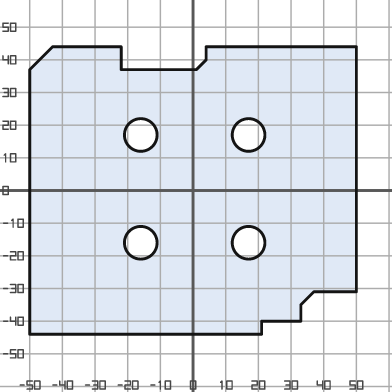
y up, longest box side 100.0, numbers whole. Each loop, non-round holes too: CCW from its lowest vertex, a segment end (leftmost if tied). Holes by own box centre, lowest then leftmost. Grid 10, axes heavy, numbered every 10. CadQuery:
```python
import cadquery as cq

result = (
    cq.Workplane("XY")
    .moveTo(-50.0, -44.0)
    .lineTo(21.0, -44.0)
    .lineTo(21.0, -40.0)
    .lineTo(33.0, -40.0)
    .lineTo(33.0, -35.0)
    .lineTo(37.0, -31.0)
    .lineTo(50.0, -31.0)
    .lineTo(50.0, 44.0)
    .lineTo(4.0, 44.0)
    .lineTo(4.0, 40.0)
    .lineTo(1.0, 37.0)
    .lineTo(-22.0, 37.0)
    .lineTo(-22.0, 44.0)
    .lineTo(-43.0, 44.0)
    .lineTo(-50.0, 37.0)
    .close()
    .moveTo(-16.0, -16.0)
    .circle(5.0)
    .moveTo(17.0, -16.0)
    .circle(5.0)
    .moveTo(-16.0, 17.0)
    .circle(5.0)
    .moveTo(17.0, 17.0)
    .circle(5.0)
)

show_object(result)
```